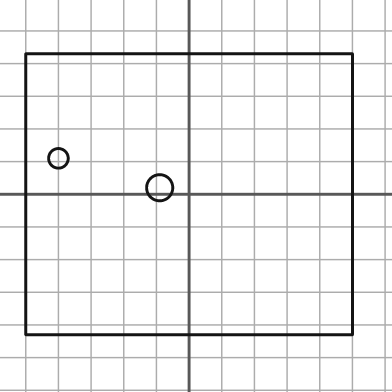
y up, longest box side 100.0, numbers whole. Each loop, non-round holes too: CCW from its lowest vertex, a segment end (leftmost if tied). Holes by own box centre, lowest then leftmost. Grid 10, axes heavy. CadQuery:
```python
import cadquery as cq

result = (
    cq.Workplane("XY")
    .moveTo(-50.0, -43.0)
    .lineTo(50.0, -43.0)
    .lineTo(50.0, 43.0)
    .lineTo(-50.0, 43.0)
    .close()
    .moveTo(-9.0, 2.0)
    .circle(4.0)
    .moveTo(-40.0, 11.0)
    .circle(3.0)
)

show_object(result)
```